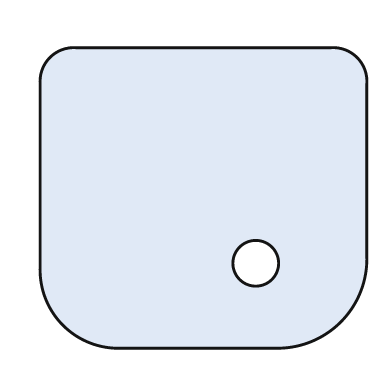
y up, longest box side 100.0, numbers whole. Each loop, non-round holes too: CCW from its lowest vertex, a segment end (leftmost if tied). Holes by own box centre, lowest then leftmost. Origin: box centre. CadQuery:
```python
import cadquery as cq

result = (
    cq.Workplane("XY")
    .moveTo(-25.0, -46.0)
    .lineTo(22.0, -46.0)
    .threePointArc((42.0, -38.0), (50.0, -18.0))
    .lineTo(50.0, 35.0)
    .threePointArc((47.0, 43.0), (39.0, 46.0))
    .lineTo(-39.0, 46.0)
    .threePointArc((-47.0, 43.0), (-50.0, 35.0))
    .lineTo(-50.0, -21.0)
    .threePointArc((-43.0, -39.0), (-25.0, -46.0))
    .close()
    .moveTo(16.0, -20.0)
    .circle(7.0)
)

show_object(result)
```